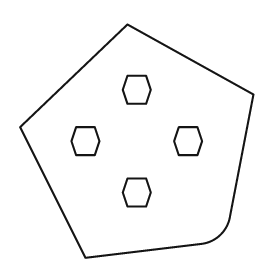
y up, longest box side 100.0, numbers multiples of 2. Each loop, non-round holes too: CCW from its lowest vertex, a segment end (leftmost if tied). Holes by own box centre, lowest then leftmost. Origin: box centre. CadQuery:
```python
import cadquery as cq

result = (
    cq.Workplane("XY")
    .moveTo(-22.0, -50.0)
    .lineTo(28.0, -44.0)
    .threePointArc((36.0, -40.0), (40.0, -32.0))
    .lineTo(50.0, 20.0)
    .lineTo(-4.0, 50.0)
    .lineTo(-50.0, 6.0)
    .close()
    .moveTo(-4.0, -28.0)
    .lineTo(4.0, -28.0)
    .lineTo(6.0, -22.0)
    .lineTo(4.0, -16.0)
    .lineTo(-4.0, -16.0)
    .lineTo(-6.0, -22.0)
    .close()
    .moveTo(-26.0, -6.0)
    .lineTo(-18.0, -6.0)
    .lineTo(-16.0, 0.0)
    .lineTo(-18.0, 6.0)
    .lineTo(-26.0, 6.0)
    .lineTo(-28.0, 0.0)
    .close()
    .moveTo(18.0, -6.0)
    .lineTo(26.0, -6.0)
    .lineTo(28.0, 0.0)
    .lineTo(26.0, 6.0)
    .lineTo(18.0, 6.0)
    .lineTo(16.0, 0.0)
    .close()
    .moveTo(-4.0, 16.0)
    .lineTo(4.0, 16.0)
    .lineTo(6.0, 22.0)
    .lineTo(4.0, 28.0)
    .lineTo(-4.0, 28.0)
    .lineTo(-6.0, 22.0)
    .close()
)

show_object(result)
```